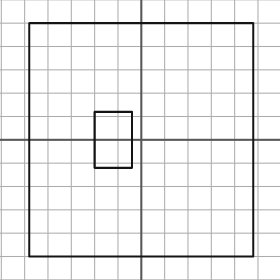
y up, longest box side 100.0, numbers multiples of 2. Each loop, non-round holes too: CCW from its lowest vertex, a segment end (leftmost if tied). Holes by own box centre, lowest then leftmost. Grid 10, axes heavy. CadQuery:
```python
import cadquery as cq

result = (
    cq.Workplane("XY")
    .moveTo(-48.0, -50.0)
    .lineTo(48.0, -50.0)
    .lineTo(48.0, 50.0)
    .lineTo(-48.0, 50.0)
    .close()
    .moveTo(-20.0, -12.0)
    .lineTo(-4.0, -12.0)
    .lineTo(-4.0, 12.0)
    .lineTo(-20.0, 12.0)
    .close()
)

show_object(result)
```